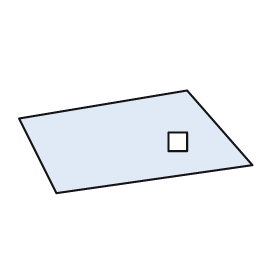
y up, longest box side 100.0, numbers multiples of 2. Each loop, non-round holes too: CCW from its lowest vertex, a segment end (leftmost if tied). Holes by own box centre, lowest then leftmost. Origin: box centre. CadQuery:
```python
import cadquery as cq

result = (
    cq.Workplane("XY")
    .moveTo(-34.0, -22.0)
    .lineTo(50.0, -10.0)
    .lineTo(22.0, 22.0)
    .lineTo(-50.0, 10.0)
    .close()
    .moveTo(14.0, -4.0)
    .lineTo(22.0, -4.0)
    .lineTo(22.0, 4.0)
    .lineTo(14.0, 4.0)
    .close()
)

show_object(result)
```